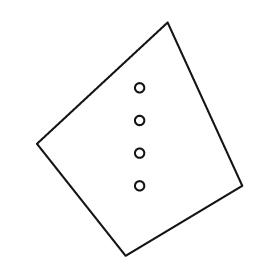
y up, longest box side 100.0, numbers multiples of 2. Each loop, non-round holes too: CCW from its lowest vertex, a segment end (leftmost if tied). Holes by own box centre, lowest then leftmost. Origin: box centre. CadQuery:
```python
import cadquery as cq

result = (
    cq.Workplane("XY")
    .moveTo(-6.0, -50.0)
    .lineTo(44.0, -20.0)
    .lineTo(12.0, 50.0)
    .lineTo(-44.0, -2.0)
    .close()
    .moveTo(0.0, -20.0)
    .circle(2.0)
    .moveTo(0.0, -6.0)
    .circle(2.0)
    .moveTo(0.0, 8.0)
    .circle(2.0)
    .moveTo(0.0, 22.0)
    .circle(2.0)
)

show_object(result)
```